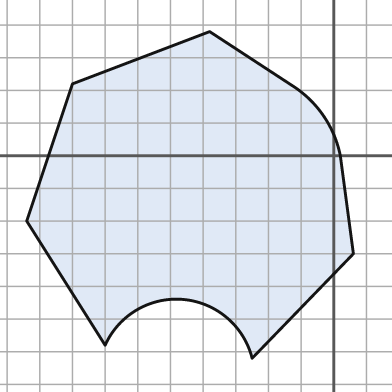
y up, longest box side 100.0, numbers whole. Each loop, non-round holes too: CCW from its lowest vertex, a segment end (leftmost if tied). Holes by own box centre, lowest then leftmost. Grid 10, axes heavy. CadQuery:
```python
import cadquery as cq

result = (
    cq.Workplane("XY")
    .moveTo(-25.0, -62.0)
    .lineTo(6.0, -30.0)
    .lineTo(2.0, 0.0)
    .threePointArc((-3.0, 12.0), (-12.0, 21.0))
    .lineTo(-38.0, 38.0)
    .lineTo(-80.0, 22.0)
    .lineTo(-94.0, -20.0)
    .lineTo(-70.0, -58.0)
    .threePointArc((-46.0, -44.0), (-25.0, -62.0))
    .close()
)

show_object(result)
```